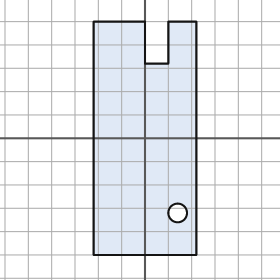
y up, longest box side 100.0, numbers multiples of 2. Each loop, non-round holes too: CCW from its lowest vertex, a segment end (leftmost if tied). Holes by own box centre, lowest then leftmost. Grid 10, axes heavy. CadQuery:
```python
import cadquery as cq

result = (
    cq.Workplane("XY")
    .moveTo(-22.0, -50.0)
    .lineTo(22.0, -50.0)
    .lineTo(22.0, 50.0)
    .lineTo(10.0, 50.0)
    .lineTo(10.0, 32.0)
    .lineTo(0.0, 32.0)
    .lineTo(0.0, 50.0)
    .lineTo(-22.0, 50.0)
    .close()
    .moveTo(14.0, -32.0)
    .circle(4.0)
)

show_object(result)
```